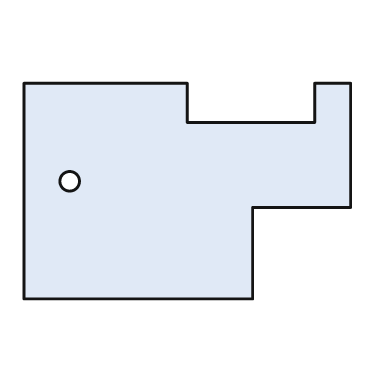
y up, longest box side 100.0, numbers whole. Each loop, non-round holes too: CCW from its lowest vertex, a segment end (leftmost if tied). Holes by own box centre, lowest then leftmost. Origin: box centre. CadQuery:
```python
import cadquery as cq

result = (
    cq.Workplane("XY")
    .moveTo(-50.0, -33.0)
    .lineTo(20.0, -33.0)
    .lineTo(20.0, -5.0)
    .lineTo(50.0, -5.0)
    .lineTo(50.0, 33.0)
    .lineTo(39.0, 33.0)
    .lineTo(39.0, 21.0)
    .lineTo(0.0, 21.0)
    .lineTo(0.0, 33.0)
    .lineTo(-50.0, 33.0)
    .close()
    .moveTo(-36.0, 3.0)
    .circle(3.0)
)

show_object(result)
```